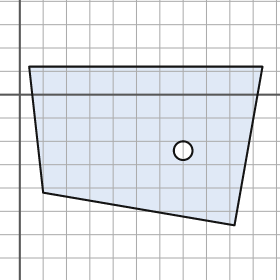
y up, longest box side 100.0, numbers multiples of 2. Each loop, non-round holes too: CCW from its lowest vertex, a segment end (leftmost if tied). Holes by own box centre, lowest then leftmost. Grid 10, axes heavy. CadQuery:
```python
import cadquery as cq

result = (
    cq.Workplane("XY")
    .moveTo(92.0, -56.0)
    .lineTo(104.0, 12.0)
    .lineTo(4.0, 12.0)
    .lineTo(10.0, -42.0)
    .close()
    .moveTo(70.0, -24.0)
    .circle(4.0)
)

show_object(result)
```